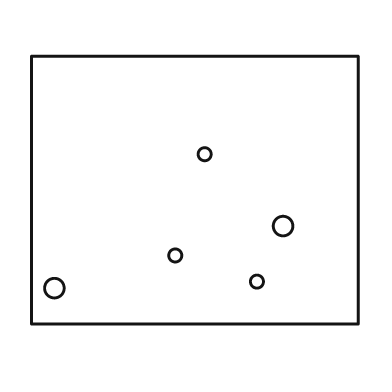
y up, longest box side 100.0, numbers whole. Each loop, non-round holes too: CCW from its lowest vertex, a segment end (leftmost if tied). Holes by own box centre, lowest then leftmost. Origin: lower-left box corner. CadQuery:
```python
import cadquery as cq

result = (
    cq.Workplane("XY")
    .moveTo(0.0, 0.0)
    .lineTo(100.0, 0.0)
    .lineTo(100.0, 82.0)
    .lineTo(0.0, 82.0)
    .close()
    .moveTo(7.0, 11.0)
    .circle(3.0)
    .moveTo(69.0, 13.0)
    .circle(2.0)
    .moveTo(44.0, 21.0)
    .circle(2.0)
    .moveTo(77.0, 30.0)
    .circle(3.0)
    .moveTo(53.0, 52.0)
    .circle(2.0)
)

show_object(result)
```